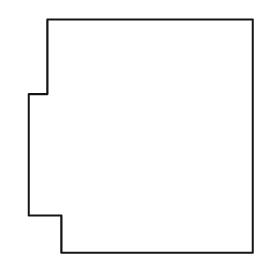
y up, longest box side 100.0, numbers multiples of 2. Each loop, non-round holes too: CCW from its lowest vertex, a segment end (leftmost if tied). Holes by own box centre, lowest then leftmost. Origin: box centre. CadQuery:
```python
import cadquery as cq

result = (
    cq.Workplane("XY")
    .moveTo(-34.0, -50.0)
    .lineTo(48.0, -50.0)
    .lineTo(48.0, 50.0)
    .lineTo(-40.0, 50.0)
    .lineTo(-40.0, 18.0)
    .lineTo(-48.0, 18.0)
    .lineTo(-48.0, -34.0)
    .lineTo(-34.0, -34.0)
    .close()
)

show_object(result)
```